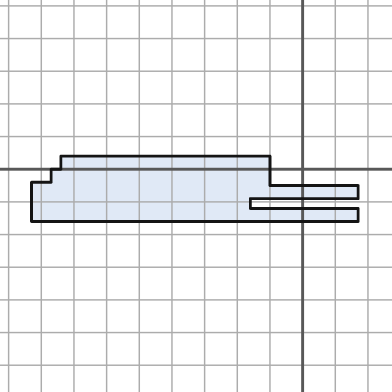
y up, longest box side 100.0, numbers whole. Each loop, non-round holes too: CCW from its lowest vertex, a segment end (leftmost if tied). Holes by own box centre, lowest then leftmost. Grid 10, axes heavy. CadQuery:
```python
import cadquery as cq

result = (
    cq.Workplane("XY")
    .moveTo(-83.0, -16.0)
    .lineTo(17.0, -16.0)
    .lineTo(17.0, -12.0)
    .lineTo(-16.0, -12.0)
    .lineTo(-16.0, -9.0)
    .lineTo(17.0, -9.0)
    .lineTo(17.0, -5.0)
    .lineTo(-10.0, -5.0)
    .lineTo(-10.0, 4.0)
    .lineTo(-74.0, 4.0)
    .lineTo(-74.0, 0.0)
    .lineTo(-77.0, 0.0)
    .lineTo(-77.0, -4.0)
    .lineTo(-83.0, -4.0)
    .close()
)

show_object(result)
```